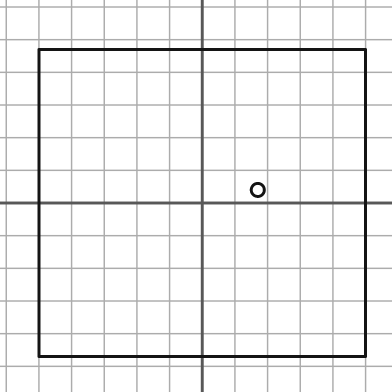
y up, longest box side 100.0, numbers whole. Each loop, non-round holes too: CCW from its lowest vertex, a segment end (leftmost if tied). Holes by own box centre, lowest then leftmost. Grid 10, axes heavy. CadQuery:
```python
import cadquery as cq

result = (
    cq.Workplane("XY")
    .moveTo(-50.0, -47.0)
    .lineTo(50.0, -47.0)
    .lineTo(50.0, 47.0)
    .lineTo(-50.0, 47.0)
    .close()
    .moveTo(17.0, 4.0)
    .circle(2.0)
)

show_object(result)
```